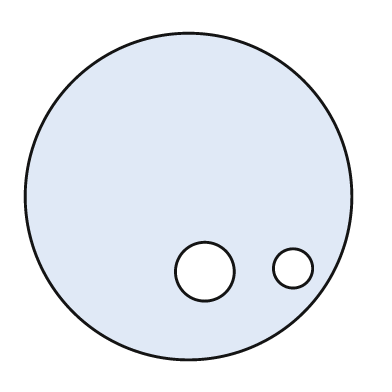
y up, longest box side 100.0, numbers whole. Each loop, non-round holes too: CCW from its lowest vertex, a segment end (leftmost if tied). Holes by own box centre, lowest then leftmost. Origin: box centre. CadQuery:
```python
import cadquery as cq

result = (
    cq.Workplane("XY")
    .moveTo(0.0, 0.0)
    .circle(50.0)
    .moveTo(5.0, -23.0)
    .circle(9.0)
    .moveTo(32.0, -22.0)
    .circle(6.0)
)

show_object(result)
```